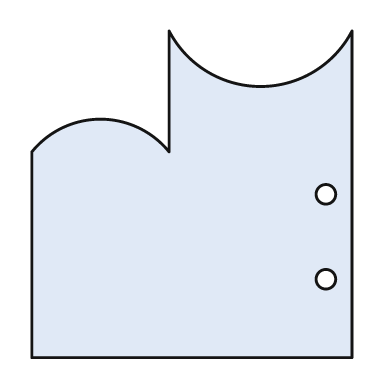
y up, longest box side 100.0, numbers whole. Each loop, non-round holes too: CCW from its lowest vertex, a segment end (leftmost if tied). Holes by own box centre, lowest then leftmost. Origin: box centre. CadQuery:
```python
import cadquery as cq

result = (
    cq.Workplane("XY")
    .moveTo(-49.0, -50.0)
    .lineTo(49.0, -50.0)
    .lineTo(49.0, 50.0)
    .threePointArc((21.0, 33.0), (-7.0, 50.0))
    .lineTo(-7.0, 13.0)
    .threePointArc((-28.0, 23.0), (-49.0, 13.0))
    .close()
    .moveTo(41.0, -26.0)
    .circle(3.0)
    .moveTo(41.0, 0.0)
    .circle(3.0)
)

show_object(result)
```